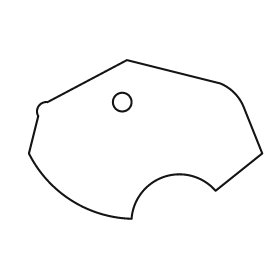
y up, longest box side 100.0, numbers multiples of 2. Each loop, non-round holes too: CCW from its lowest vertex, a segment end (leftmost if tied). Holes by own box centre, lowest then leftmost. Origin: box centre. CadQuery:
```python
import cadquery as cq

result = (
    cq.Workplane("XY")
    .moveTo(-6.0, -34.0)
    .threePointArc((8.0, -16.0), (30.0, -22.0))
    .lineTo(50.0, -6.0)
    .lineTo(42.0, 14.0)
    .threePointArc((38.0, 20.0), (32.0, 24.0))
    .lineTo(-8.0, 34.0)
    .lineTo(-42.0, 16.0)
    .threePointArc((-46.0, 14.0), (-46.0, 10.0))
    .lineTo(-50.0, -6.0)
    .threePointArc((-32.0, -26.0), (-6.0, -34.0))
    .close()
    .moveTo(-10.0, 16.0)
    .circle(4.0)
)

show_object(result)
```